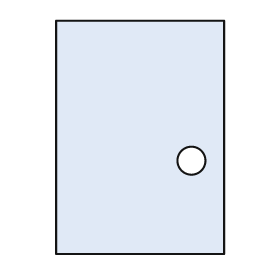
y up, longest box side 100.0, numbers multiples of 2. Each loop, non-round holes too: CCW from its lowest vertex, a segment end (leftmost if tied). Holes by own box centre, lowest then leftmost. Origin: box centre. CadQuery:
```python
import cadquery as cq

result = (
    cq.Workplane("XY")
    .moveTo(-36.0, -50.0)
    .lineTo(36.0, -50.0)
    .lineTo(36.0, 50.0)
    .lineTo(-36.0, 50.0)
    .close()
    .moveTo(22.0, -10.0)
    .circle(6.0)
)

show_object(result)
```